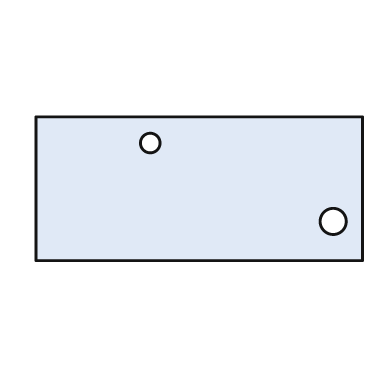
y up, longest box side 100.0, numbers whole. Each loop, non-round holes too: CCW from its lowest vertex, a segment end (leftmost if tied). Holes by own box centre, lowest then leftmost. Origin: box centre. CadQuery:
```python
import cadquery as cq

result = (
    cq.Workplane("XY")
    .moveTo(-50.0, -22.0)
    .lineTo(50.0, -22.0)
    .lineTo(50.0, 22.0)
    .lineTo(-50.0, 22.0)
    .close()
    .moveTo(41.0, -10.0)
    .circle(4.0)
    .moveTo(-15.0, 14.0)
    .circle(3.0)
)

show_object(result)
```